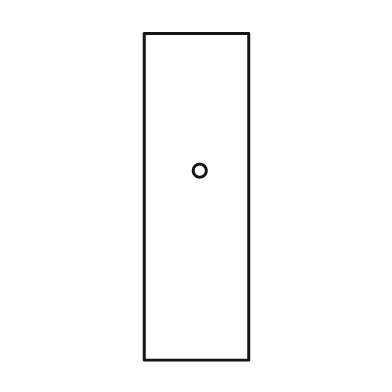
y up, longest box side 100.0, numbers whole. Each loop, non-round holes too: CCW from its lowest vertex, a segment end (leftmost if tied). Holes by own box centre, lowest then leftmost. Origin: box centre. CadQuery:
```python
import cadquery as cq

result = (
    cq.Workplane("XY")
    .moveTo(-16.0, -50.0)
    .lineTo(16.0, -50.0)
    .lineTo(16.0, 50.0)
    .lineTo(-16.0, 50.0)
    .close()
    .moveTo(1.0, 8.0)
    .circle(2.0)
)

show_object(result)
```